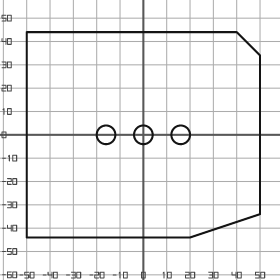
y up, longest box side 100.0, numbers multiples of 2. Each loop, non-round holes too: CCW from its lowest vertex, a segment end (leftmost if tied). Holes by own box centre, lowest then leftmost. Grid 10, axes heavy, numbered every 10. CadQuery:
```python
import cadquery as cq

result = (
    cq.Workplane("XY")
    .moveTo(-50.0, -44.0)
    .lineTo(20.0, -44.0)
    .lineTo(50.0, -34.0)
    .lineTo(50.0, 34.0)
    .lineTo(40.0, 44.0)
    .lineTo(-50.0, 44.0)
    .close()
    .moveTo(-16.0, 0.0)
    .circle(4.0)
    .moveTo(0.0, 0.0)
    .circle(4.0)
    .moveTo(16.0, 0.0)
    .circle(4.0)
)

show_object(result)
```